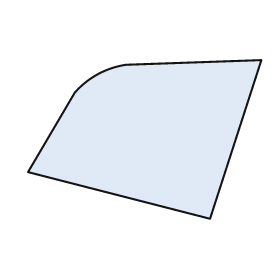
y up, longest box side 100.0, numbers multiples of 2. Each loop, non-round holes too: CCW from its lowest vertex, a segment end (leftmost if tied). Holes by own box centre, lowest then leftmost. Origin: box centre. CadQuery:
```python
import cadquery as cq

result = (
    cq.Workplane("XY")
    .moveTo(28.0, -34.0)
    .lineTo(50.0, 34.0)
    .lineTo(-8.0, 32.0)
    .threePointArc((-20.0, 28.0), (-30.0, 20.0))
    .lineTo(-50.0, -14.0)
    .close()
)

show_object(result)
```